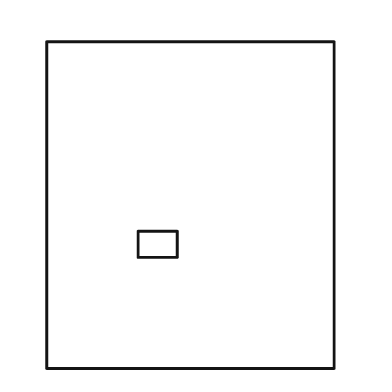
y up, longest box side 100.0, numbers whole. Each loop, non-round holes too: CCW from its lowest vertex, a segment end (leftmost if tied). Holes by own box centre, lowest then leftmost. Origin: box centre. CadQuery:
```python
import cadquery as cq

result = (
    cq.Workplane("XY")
    .moveTo(-44.0, -50.0)
    .lineTo(44.0, -50.0)
    .lineTo(44.0, 50.0)
    .lineTo(-44.0, 50.0)
    .close()
    .moveTo(-16.0, -16.0)
    .lineTo(-4.0, -16.0)
    .lineTo(-4.0, -8.0)
    .lineTo(-16.0, -8.0)
    .close()
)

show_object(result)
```